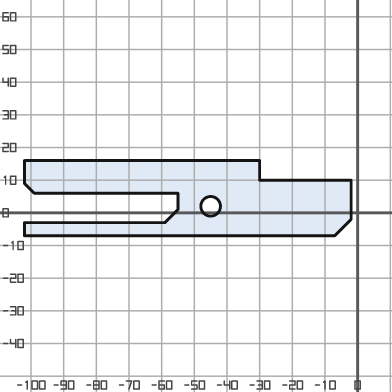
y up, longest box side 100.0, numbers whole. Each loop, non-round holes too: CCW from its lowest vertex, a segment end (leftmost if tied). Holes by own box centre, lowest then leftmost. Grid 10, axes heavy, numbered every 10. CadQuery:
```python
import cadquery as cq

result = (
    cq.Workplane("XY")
    .moveTo(-102.0, -7.0)
    .lineTo(-7.0, -7.0)
    .lineTo(-2.0, -2.0)
    .lineTo(-2.0, 10.0)
    .lineTo(-30.0, 10.0)
    .lineTo(-30.0, 16.0)
    .lineTo(-102.0, 16.0)
    .lineTo(-102.0, 9.0)
    .lineTo(-99.0, 6.0)
    .lineTo(-55.0, 6.0)
    .lineTo(-55.0, 1.0)
    .lineTo(-59.0, -3.0)
    .lineTo(-102.0, -3.0)
    .close()
    .moveTo(-45.0, 2.0)
    .circle(3.0)
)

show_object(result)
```